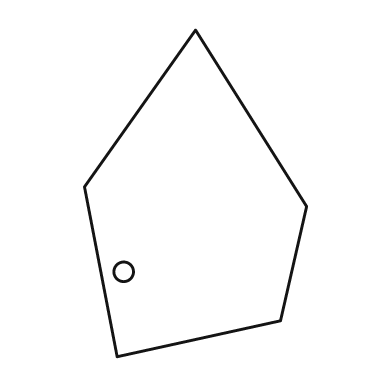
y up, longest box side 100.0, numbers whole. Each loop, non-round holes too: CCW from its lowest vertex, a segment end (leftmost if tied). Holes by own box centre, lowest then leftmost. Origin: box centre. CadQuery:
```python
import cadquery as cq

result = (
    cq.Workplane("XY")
    .moveTo(-24.0, -50.0)
    .lineTo(26.0, -39.0)
    .lineTo(34.0, -4.0)
    .lineTo(0.0, 50.0)
    .lineTo(-34.0, 2.0)
    .close()
    .moveTo(-22.0, -24.0)
    .circle(3.0)
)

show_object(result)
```